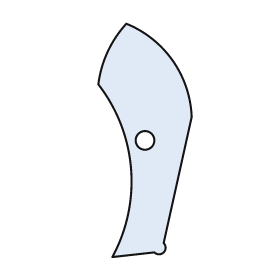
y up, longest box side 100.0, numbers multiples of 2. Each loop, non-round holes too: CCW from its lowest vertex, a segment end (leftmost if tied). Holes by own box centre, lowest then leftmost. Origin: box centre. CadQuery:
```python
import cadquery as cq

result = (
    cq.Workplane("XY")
    .moveTo(-14.0, -50.0)
    .lineTo(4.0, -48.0)
    .threePointArc((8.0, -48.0), (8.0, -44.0))
    .lineTo(20.0, 10.0)
    .threePointArc((12.0, 34.0), (-8.0, 50.0))
    .threePointArc((-16.0, 38.0), (-20.0, 24.0))
    .threePointArc((-6.0, -12.0), (-14.0, -50.0))
    .close()
    .moveTo(0.0, 0.0)
    .circle(4.0)
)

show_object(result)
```